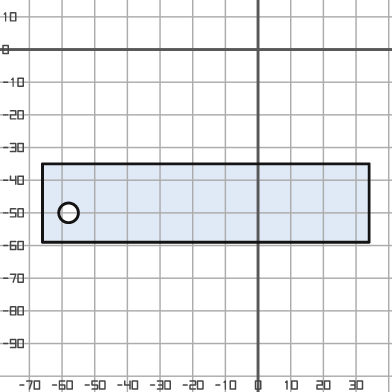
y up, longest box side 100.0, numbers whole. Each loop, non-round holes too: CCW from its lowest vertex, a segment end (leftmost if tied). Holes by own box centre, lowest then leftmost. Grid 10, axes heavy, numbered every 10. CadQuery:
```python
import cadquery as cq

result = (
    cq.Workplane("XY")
    .moveTo(-66.0, -59.0)
    .lineTo(34.0, -59.0)
    .lineTo(34.0, -35.0)
    .lineTo(-66.0, -35.0)
    .close()
    .moveTo(-58.0, -50.0)
    .circle(3.0)
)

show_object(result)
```